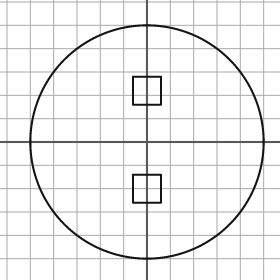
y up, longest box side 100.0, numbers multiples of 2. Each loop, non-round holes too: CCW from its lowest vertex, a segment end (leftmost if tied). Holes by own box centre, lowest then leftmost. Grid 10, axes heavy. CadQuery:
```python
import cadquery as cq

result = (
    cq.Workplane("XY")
    .moveTo(0.0, 0.0)
    .circle(50.0)
    .moveTo(-6.0, -26.0)
    .lineTo(6.0, -26.0)
    .lineTo(6.0, -14.0)
    .lineTo(-6.0, -14.0)
    .close()
    .moveTo(-6.0, 16.0)
    .lineTo(6.0, 16.0)
    .lineTo(6.0, 28.0)
    .lineTo(-6.0, 28.0)
    .close()
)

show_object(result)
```